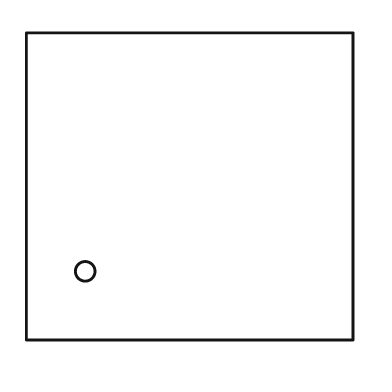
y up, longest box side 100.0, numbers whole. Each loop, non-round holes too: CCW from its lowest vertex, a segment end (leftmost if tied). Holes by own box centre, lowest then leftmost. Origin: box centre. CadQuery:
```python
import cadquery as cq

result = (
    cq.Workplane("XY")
    .moveTo(-50.0, -47.0)
    .lineTo(50.0, -47.0)
    .lineTo(50.0, 47.0)
    .lineTo(-50.0, 47.0)
    .close()
    .moveTo(-32.0, -26.0)
    .circle(3.0)
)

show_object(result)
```